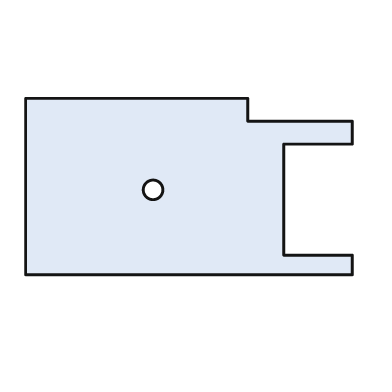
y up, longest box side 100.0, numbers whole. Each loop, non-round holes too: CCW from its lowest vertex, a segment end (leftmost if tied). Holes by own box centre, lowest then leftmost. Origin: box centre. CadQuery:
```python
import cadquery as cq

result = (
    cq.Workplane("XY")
    .moveTo(-50.0, -27.0)
    .lineTo(50.0, -27.0)
    .lineTo(50.0, -21.0)
    .lineTo(29.0, -21.0)
    .lineTo(29.0, 13.0)
    .lineTo(50.0, 13.0)
    .lineTo(50.0, 20.0)
    .lineTo(18.0, 20.0)
    .lineTo(18.0, 27.0)
    .lineTo(-50.0, 27.0)
    .close()
    .moveTo(-11.0, -1.0)
    .circle(3.0)
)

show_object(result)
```